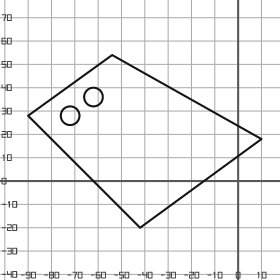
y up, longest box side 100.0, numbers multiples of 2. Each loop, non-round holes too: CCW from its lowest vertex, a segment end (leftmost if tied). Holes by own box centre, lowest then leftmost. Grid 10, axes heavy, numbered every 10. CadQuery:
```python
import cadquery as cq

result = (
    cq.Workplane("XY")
    .moveTo(-42.0, -20.0)
    .lineTo(10.0, 18.0)
    .lineTo(-54.0, 54.0)
    .lineTo(-90.0, 28.0)
    .close()
    .moveTo(-72.0, 28.0)
    .circle(4.0)
    .moveTo(-62.0, 36.0)
    .circle(4.0)
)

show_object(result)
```